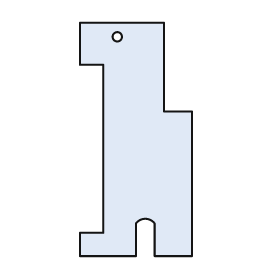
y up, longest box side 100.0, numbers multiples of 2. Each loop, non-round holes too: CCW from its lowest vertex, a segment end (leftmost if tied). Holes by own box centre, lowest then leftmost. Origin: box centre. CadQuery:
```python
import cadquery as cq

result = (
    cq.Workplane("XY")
    .moveTo(-24.0, -50.0)
    .lineTo(0.0, -50.0)
    .lineTo(0.0, -36.0)
    .threePointArc((4.0, -34.0), (8.0, -36.0))
    .lineTo(8.0, -50.0)
    .lineTo(24.0, -50.0)
    .lineTo(24.0, 12.0)
    .lineTo(12.0, 12.0)
    .lineTo(12.0, 50.0)
    .lineTo(-24.0, 50.0)
    .lineTo(-24.0, 32.0)
    .lineTo(-14.0, 32.0)
    .lineTo(-14.0, -40.0)
    .lineTo(-24.0, -40.0)
    .close()
    .moveTo(-8.0, 44.0)
    .circle(2.0)
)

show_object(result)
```